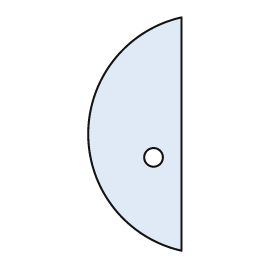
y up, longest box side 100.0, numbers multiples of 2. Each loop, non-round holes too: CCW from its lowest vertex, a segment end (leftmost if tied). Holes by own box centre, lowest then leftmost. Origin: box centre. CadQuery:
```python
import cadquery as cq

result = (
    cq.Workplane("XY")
    .moveTo(20.0, -50.0)
    .lineTo(20.0, 50.0)
    .threePointArc((-20.0, 0.0), (20.0, -50.0))
    .close()
    .moveTo(8.0, -10.0)
    .circle(4.0)
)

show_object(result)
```